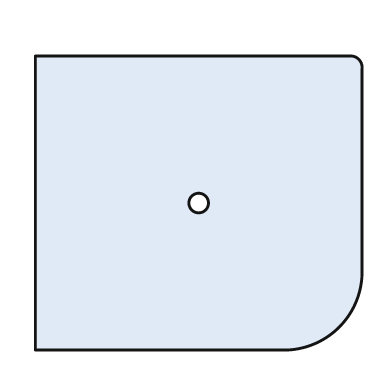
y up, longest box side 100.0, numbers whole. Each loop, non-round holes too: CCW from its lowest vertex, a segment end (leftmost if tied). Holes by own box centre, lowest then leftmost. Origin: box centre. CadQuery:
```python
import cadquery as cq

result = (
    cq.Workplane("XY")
    .moveTo(-50.0, -45.0)
    .lineTo(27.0, -45.0)
    .threePointArc((43.0, -38.0), (50.0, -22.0))
    .lineTo(50.0, 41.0)
    .threePointArc((49.0, 44.0), (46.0, 45.0))
    .lineTo(-50.0, 45.0)
    .close()
    .moveTo(0.0, 0.0)
    .circle(3.0)
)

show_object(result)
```